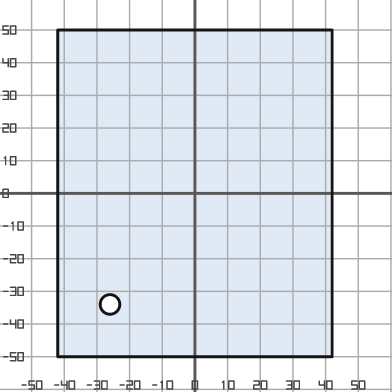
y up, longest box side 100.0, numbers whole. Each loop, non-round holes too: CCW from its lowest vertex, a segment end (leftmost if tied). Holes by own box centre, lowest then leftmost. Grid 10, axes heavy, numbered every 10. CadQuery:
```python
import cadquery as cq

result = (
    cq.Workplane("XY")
    .moveTo(-42.0, -50.0)
    .lineTo(42.0, -50.0)
    .lineTo(42.0, 50.0)
    .lineTo(-42.0, 50.0)
    .close()
    .moveTo(-26.0, -34.0)
    .circle(3.0)
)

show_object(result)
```